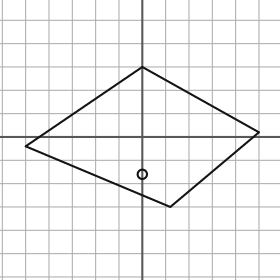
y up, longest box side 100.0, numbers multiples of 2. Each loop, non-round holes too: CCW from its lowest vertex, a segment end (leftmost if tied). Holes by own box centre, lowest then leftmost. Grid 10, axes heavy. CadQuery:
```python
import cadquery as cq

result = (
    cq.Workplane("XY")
    .moveTo(12.0, -30.0)
    .lineTo(50.0, 2.0)
    .lineTo(0.0, 30.0)
    .lineTo(-50.0, -4.0)
    .close()
    .moveTo(0.0, -16.0)
    .circle(2.0)
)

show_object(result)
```